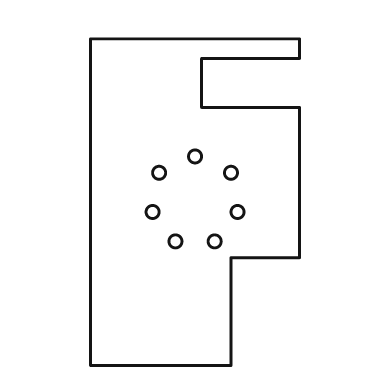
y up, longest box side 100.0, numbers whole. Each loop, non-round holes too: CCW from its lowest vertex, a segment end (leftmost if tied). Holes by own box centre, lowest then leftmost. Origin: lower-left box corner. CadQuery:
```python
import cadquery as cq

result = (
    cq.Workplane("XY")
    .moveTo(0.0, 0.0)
    .lineTo(43.0, 0.0)
    .lineTo(43.0, 33.0)
    .lineTo(64.0, 33.0)
    .lineTo(64.0, 79.0)
    .lineTo(34.0, 79.0)
    .lineTo(34.0, 94.0)
    .lineTo(64.0, 94.0)
    .lineTo(64.0, 100.0)
    .lineTo(0.0, 100.0)
    .close()
    .moveTo(26.0, 38.0)
    .circle(2.0)
    .moveTo(38.0, 38.0)
    .circle(2.0)
    .moveTo(19.0, 47.0)
    .circle(2.0)
    .moveTo(45.0, 47.0)
    .circle(2.0)
    .moveTo(21.0, 59.0)
    .circle(2.0)
    .moveTo(43.0, 59.0)
    .circle(2.0)
    .moveTo(32.0, 64.0)
    .circle(2.0)
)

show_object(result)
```